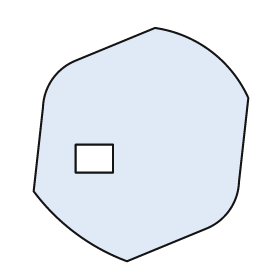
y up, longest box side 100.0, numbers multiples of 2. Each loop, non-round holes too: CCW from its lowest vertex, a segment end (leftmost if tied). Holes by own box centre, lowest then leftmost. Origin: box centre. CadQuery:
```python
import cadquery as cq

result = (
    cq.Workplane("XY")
    .moveTo(-6.0, -50.0)
    .lineTo(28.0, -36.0)
    .threePointArc((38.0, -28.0), (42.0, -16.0))
    .lineTo(46.0, 20.0)
    .threePointArc((30.0, 40.0), (6.0, 50.0))
    .lineTo(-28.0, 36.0)
    .threePointArc((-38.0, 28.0), (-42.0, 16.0))
    .lineTo(-46.0, -20.0)
    .threePointArc((-28.0, -38.0), (-6.0, -50.0))
    .close()
    .moveTo(-28.0, -12.0)
    .lineTo(-12.0, -12.0)
    .lineTo(-12.0, 0.0)
    .lineTo(-28.0, 0.0)
    .close()
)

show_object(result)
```